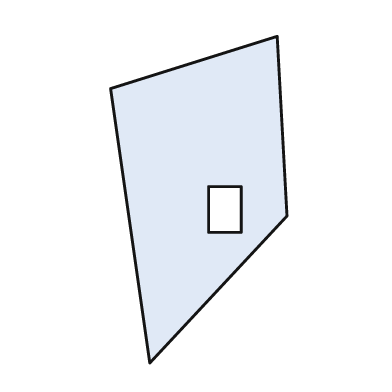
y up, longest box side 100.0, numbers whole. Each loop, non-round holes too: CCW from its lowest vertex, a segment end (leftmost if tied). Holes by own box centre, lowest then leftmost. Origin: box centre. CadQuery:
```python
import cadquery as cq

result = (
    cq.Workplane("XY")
    .moveTo(-15.0, -50.0)
    .lineTo(27.0, -5.0)
    .lineTo(24.0, 50.0)
    .lineTo(-27.0, 34.0)
    .close()
    .moveTo(3.0, -10.0)
    .lineTo(13.0, -10.0)
    .lineTo(13.0, 4.0)
    .lineTo(3.0, 4.0)
    .close()
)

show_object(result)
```